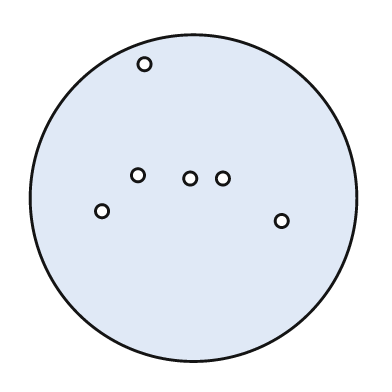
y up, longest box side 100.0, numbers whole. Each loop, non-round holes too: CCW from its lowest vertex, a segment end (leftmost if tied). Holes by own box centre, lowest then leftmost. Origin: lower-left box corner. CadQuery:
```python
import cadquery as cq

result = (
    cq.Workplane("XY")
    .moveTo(50.0, 50.0)
    .circle(50.0)
    .moveTo(77.0, 43.0)
    .circle(2.0)
    .moveTo(22.0, 46.0)
    .circle(2.0)
    .moveTo(49.0, 56.0)
    .circle(2.0)
    .moveTo(59.0, 56.0)
    .circle(2.0)
    .moveTo(33.0, 57.0)
    .circle(2.0)
    .moveTo(35.0, 91.0)
    .circle(2.0)
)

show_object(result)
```